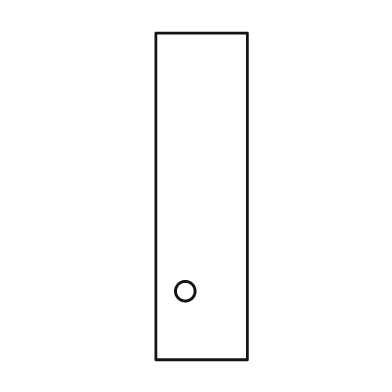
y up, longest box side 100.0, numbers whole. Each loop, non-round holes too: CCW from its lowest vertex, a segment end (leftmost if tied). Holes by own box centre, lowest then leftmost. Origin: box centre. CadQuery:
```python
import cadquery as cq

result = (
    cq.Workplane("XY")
    .moveTo(-14.0, -50.0)
    .lineTo(14.0, -50.0)
    .lineTo(14.0, 50.0)
    .lineTo(-14.0, 50.0)
    .close()
    .moveTo(-5.0, -29.0)
    .circle(3.0)
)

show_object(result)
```